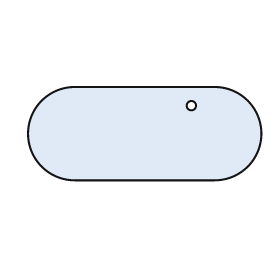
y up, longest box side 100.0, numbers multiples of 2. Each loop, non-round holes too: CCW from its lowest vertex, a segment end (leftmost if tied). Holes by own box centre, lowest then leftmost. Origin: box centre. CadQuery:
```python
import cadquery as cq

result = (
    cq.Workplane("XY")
    .moveTo(-30.0, -20.0)
    .lineTo(30.0, -20.0)
    .threePointArc((50.0, 0.0), (30.0, 20.0))
    .lineTo(-30.0, 20.0)
    .threePointArc((-50.0, 0.0), (-30.0, -20.0))
    .close()
    .moveTo(20.0, 12.0)
    .circle(2.0)
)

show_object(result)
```